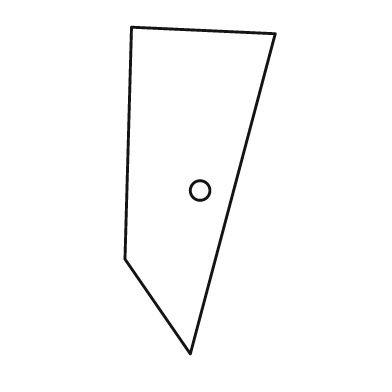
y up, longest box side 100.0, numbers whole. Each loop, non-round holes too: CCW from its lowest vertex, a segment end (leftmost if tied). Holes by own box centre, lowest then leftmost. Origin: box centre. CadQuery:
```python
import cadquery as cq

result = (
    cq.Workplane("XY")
    .moveTo(-3.0, -50.0)
    .lineTo(23.0, 48.0)
    .lineTo(-21.0, 50.0)
    .lineTo(-23.0, -21.0)
    .close()
    .moveTo(0.0, 0.0)
    .circle(3.0)
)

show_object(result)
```